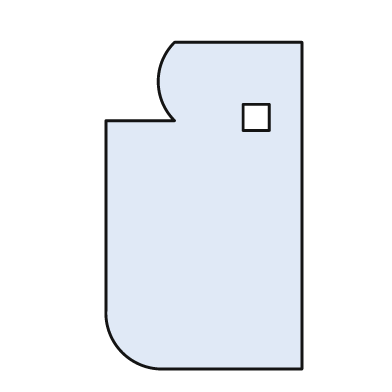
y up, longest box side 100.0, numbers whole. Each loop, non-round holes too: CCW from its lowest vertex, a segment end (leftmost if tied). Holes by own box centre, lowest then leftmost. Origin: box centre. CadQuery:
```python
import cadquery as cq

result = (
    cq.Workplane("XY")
    .moveTo(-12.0, -50.0)
    .lineTo(30.0, -50.0)
    .lineTo(30.0, 50.0)
    .lineTo(-9.0, 50.0)
    .threePointArc((-14.0, 38.0), (-9.0, 26.0))
    .lineTo(-30.0, 26.0)
    .lineTo(-30.0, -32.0)
    .threePointArc((-25.0, -45.0), (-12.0, -50.0))
    .close()
    .moveTo(12.0, 23.0)
    .lineTo(20.0, 23.0)
    .lineTo(20.0, 31.0)
    .lineTo(12.0, 31.0)
    .close()
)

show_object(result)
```